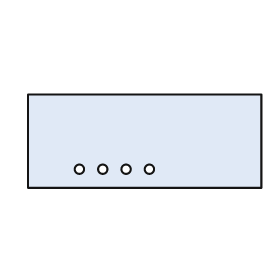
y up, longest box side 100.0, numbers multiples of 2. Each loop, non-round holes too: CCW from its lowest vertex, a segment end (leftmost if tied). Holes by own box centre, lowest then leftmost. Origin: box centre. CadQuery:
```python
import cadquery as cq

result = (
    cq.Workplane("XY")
    .moveTo(-50.0, -20.0)
    .lineTo(50.0, -20.0)
    .lineTo(50.0, 20.0)
    .lineTo(-50.0, 20.0)
    .close()
    .moveTo(-28.0, -12.0)
    .circle(2.0)
    .moveTo(-18.0, -12.0)
    .circle(2.0)
    .moveTo(-8.0, -12.0)
    .circle(2.0)
    .moveTo(2.0, -12.0)
    .circle(2.0)
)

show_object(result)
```